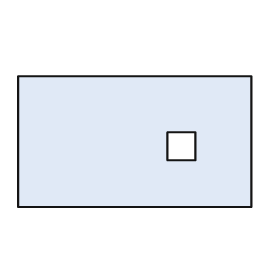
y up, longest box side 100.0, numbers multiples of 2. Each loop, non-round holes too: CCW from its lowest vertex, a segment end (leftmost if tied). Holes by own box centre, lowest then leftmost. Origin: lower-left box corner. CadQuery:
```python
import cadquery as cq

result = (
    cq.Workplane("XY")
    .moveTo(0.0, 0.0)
    .lineTo(100.0, 0.0)
    .lineTo(100.0, 56.0)
    .lineTo(0.0, 56.0)
    .close()
    .moveTo(64.0, 20.0)
    .lineTo(76.0, 20.0)
    .lineTo(76.0, 32.0)
    .lineTo(64.0, 32.0)
    .close()
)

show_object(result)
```